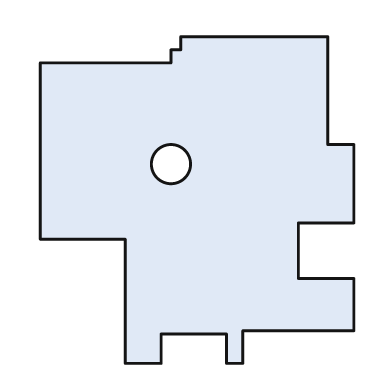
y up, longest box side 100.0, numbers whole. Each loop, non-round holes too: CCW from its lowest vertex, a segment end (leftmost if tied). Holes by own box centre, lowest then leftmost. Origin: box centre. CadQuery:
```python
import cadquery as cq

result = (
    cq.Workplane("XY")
    .moveTo(-22.0, -50.0)
    .lineTo(-11.0, -50.0)
    .lineTo(-11.0, -41.0)
    .lineTo(9.0, -41.0)
    .lineTo(9.0, -50.0)
    .lineTo(14.0, -50.0)
    .lineTo(14.0, -40.0)
    .lineTo(48.0, -40.0)
    .lineTo(48.0, -24.0)
    .lineTo(31.0, -24.0)
    .lineTo(31.0, -7.0)
    .lineTo(48.0, -7.0)
    .lineTo(48.0, 17.0)
    .lineTo(40.0, 17.0)
    .lineTo(40.0, 50.0)
    .lineTo(-5.0, 50.0)
    .lineTo(-5.0, 46.0)
    .lineTo(-8.0, 46.0)
    .lineTo(-8.0, 42.0)
    .lineTo(-48.0, 42.0)
    .lineTo(-48.0, -12.0)
    .lineTo(-22.0, -12.0)
    .close()
    .moveTo(-8.0, 11.0)
    .circle(6.0)
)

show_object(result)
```